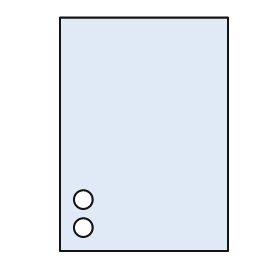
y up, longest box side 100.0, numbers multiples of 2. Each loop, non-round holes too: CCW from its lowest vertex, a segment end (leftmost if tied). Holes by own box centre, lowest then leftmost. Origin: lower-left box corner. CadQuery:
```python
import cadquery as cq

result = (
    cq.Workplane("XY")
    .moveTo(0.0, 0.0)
    .lineTo(72.0, 0.0)
    .lineTo(72.0, 100.0)
    .lineTo(0.0, 100.0)
    .close()
    .moveTo(10.0, 10.0)
    .circle(4.0)
    .moveTo(10.0, 22.0)
    .circle(4.0)
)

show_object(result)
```